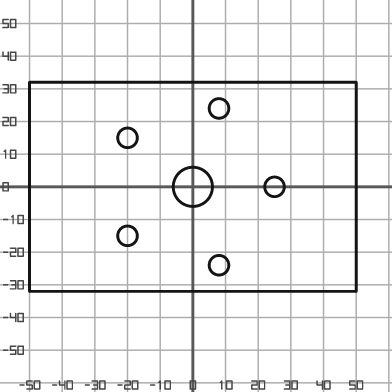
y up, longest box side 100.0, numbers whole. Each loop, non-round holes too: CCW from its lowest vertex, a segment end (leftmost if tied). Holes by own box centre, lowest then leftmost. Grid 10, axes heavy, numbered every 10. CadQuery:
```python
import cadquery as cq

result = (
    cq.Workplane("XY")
    .moveTo(-50.0, -32.0)
    .lineTo(50.0, -32.0)
    .lineTo(50.0, 32.0)
    .lineTo(-50.0, 32.0)
    .close()
    .moveTo(8.0, -24.0)
    .circle(3.0)
    .moveTo(-20.0, -15.0)
    .circle(3.0)
    .moveTo(0.0, 0.0)
    .circle(6.0)
    .moveTo(25.0, 0.0)
    .circle(3.0)
    .moveTo(-20.0, 15.0)
    .circle(3.0)
    .moveTo(8.0, 24.0)
    .circle(3.0)
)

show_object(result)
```